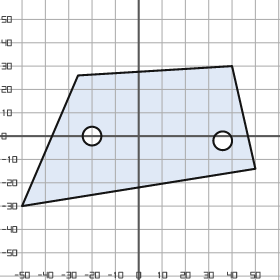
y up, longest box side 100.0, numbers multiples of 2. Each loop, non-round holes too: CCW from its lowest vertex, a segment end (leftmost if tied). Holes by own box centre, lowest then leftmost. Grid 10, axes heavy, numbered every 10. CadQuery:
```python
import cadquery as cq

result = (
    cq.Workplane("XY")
    .moveTo(-50.0, -30.0)
    .lineTo(50.0, -14.0)
    .lineTo(40.0, 30.0)
    .lineTo(-26.0, 26.0)
    .close()
    .moveTo(36.0, -2.0)
    .circle(4.0)
    .moveTo(-20.0, 0.0)
    .circle(4.0)
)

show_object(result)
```